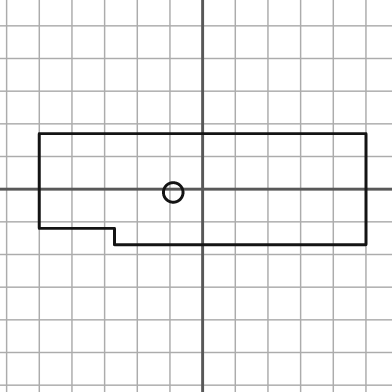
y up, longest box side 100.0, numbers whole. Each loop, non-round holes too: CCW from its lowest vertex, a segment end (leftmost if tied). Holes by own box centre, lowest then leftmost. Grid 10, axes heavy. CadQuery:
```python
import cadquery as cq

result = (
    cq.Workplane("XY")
    .moveTo(-27.0, -17.0)
    .lineTo(50.0, -17.0)
    .lineTo(50.0, 17.0)
    .lineTo(-50.0, 17.0)
    .lineTo(-50.0, -12.0)
    .lineTo(-27.0, -12.0)
    .close()
    .moveTo(-9.0, -1.0)
    .circle(3.0)
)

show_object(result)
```